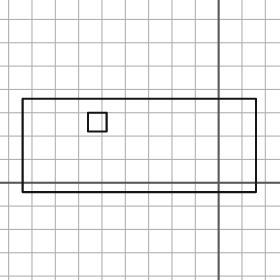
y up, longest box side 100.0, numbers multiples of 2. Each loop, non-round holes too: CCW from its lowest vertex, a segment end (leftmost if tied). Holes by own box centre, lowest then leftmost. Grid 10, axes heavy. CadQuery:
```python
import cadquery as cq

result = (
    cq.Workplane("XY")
    .moveTo(-84.0, -4.0)
    .lineTo(16.0, -4.0)
    .lineTo(16.0, 36.0)
    .lineTo(-84.0, 36.0)
    .close()
    .moveTo(-56.0, 22.0)
    .lineTo(-48.0, 22.0)
    .lineTo(-48.0, 30.0)
    .lineTo(-56.0, 30.0)
    .close()
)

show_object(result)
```